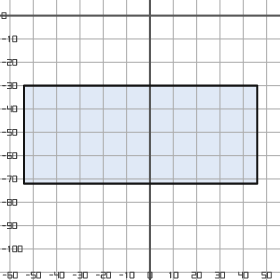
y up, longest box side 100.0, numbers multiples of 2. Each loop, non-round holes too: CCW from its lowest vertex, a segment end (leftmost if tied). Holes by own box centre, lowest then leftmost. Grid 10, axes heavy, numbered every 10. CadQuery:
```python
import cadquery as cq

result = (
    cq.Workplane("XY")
    .moveTo(-54.0, -72.0)
    .lineTo(46.0, -72.0)
    .lineTo(46.0, -30.0)
    .lineTo(-54.0, -30.0)
    .close()
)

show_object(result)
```